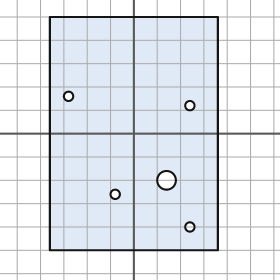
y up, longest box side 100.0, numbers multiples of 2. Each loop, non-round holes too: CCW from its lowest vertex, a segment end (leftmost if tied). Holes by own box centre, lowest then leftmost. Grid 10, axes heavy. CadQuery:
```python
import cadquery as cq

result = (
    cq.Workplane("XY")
    .moveTo(-36.0, -50.0)
    .lineTo(36.0, -50.0)
    .lineTo(36.0, 50.0)
    .lineTo(-36.0, 50.0)
    .close()
    .moveTo(24.0, -40.0)
    .circle(2.0)
    .moveTo(-8.0, -26.0)
    .circle(2.0)
    .moveTo(14.0, -20.0)
    .circle(4.0)
    .moveTo(24.0, 12.0)
    .circle(2.0)
    .moveTo(-28.0, 16.0)
    .circle(2.0)
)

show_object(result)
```